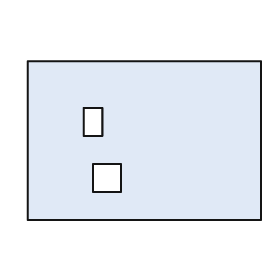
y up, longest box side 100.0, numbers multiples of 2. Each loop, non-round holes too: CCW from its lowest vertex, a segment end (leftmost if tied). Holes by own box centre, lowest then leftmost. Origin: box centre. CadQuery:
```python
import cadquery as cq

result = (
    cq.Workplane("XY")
    .moveTo(-50.0, -34.0)
    .lineTo(50.0, -34.0)
    .lineTo(50.0, 34.0)
    .lineTo(-50.0, 34.0)
    .close()
    .moveTo(-22.0, -22.0)
    .lineTo(-10.0, -22.0)
    .lineTo(-10.0, -10.0)
    .lineTo(-22.0, -10.0)
    .close()
    .moveTo(-26.0, 2.0)
    .lineTo(-18.0, 2.0)
    .lineTo(-18.0, 14.0)
    .lineTo(-26.0, 14.0)
    .close()
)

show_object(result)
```